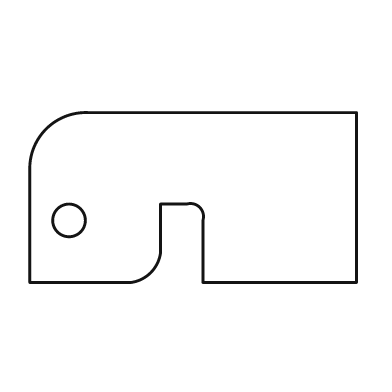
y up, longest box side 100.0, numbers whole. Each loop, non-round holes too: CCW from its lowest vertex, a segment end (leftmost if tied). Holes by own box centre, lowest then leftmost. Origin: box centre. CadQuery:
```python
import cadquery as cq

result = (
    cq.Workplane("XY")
    .moveTo(-50.0, -26.0)
    .lineTo(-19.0, -26.0)
    .threePointArc((-13.0, -23.0), (-10.0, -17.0))
    .lineTo(-10.0, -2.0)
    .lineTo(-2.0, -2.0)
    .threePointArc((2.0, -3.0), (3.0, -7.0))
    .lineTo(3.0, -26.0)
    .lineTo(50.0, -26.0)
    .lineTo(50.0, 26.0)
    .lineTo(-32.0, 26.0)
    .threePointArc((-45.0, 21.0), (-50.0, 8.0))
    .close()
    .moveTo(-38.0, -7.0)
    .circle(5.0)
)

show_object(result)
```